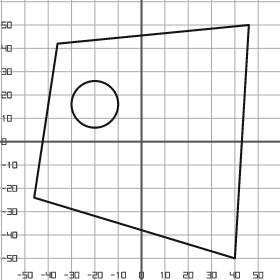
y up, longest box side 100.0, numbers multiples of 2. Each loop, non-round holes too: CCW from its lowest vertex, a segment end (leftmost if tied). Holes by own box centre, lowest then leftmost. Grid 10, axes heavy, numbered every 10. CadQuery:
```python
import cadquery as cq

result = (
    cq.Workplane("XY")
    .moveTo(40.0, -50.0)
    .lineTo(46.0, 50.0)
    .lineTo(-36.0, 42.0)
    .lineTo(-46.0, -24.0)
    .close()
    .moveTo(-20.0, 16.0)
    .circle(10.0)
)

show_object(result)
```